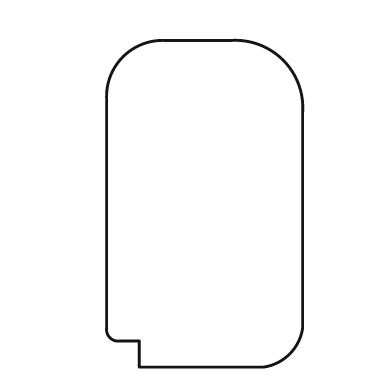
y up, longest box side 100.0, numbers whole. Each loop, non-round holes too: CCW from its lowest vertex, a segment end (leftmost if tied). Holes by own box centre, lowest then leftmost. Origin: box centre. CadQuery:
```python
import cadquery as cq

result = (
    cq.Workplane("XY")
    .moveTo(-20.0, -50.0)
    .lineTo(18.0, -50.0)
    .threePointArc((26.0, -46.0), (30.0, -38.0))
    .lineTo(30.0, 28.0)
    .threePointArc((24.0, 44.0), (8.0, 50.0))
    .lineTo(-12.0, 50.0)
    .threePointArc((-25.0, 45.0), (-30.0, 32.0))
    .lineTo(-30.0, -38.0)
    .threePointArc((-29.0, -41.0), (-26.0, -42.0))
    .lineTo(-20.0, -42.0)
    .close()
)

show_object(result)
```